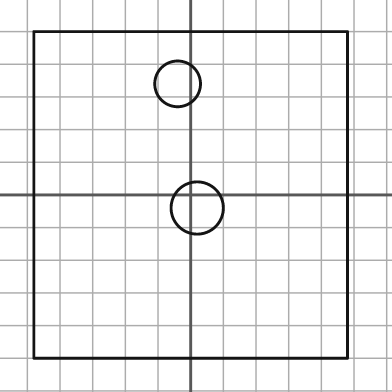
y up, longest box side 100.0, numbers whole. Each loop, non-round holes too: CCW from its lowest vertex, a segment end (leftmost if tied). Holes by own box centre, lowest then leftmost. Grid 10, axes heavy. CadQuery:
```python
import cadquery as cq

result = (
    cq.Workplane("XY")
    .moveTo(-48.0, -50.0)
    .lineTo(48.0, -50.0)
    .lineTo(48.0, 50.0)
    .lineTo(-48.0, 50.0)
    .close()
    .moveTo(2.0, -4.0)
    .circle(8.0)
    .moveTo(-4.0, 34.0)
    .circle(7.0)
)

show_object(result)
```